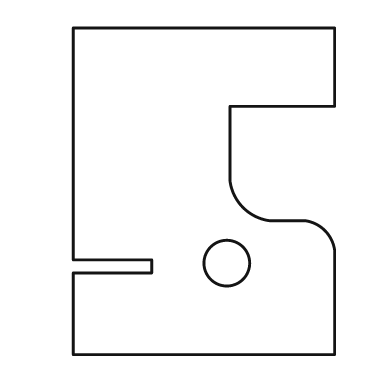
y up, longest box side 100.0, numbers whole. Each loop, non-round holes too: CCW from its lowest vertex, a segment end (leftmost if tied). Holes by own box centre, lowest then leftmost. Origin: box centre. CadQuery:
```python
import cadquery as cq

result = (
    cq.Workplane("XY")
    .moveTo(-40.0, -50.0)
    .lineTo(40.0, -50.0)
    .lineTo(40.0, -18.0)
    .threePointArc((37.0, -12.0), (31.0, -9.0))
    .lineTo(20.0, -9.0)
    .threePointArc((12.0, -5.0), (8.0, 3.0))
    .lineTo(8.0, 26.0)
    .lineTo(40.0, 26.0)
    .lineTo(40.0, 50.0)
    .lineTo(-40.0, 50.0)
    .lineTo(-40.0, -21.0)
    .lineTo(-16.0, -21.0)
    .lineTo(-16.0, -25.0)
    .lineTo(-40.0, -25.0)
    .close()
    .moveTo(7.0, -22.0)
    .circle(7.0)
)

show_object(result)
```